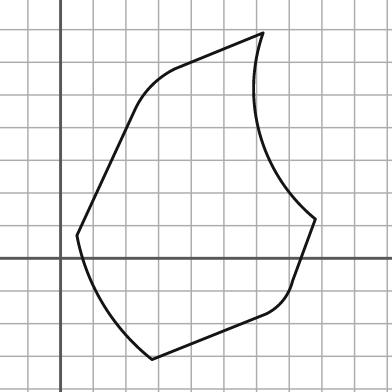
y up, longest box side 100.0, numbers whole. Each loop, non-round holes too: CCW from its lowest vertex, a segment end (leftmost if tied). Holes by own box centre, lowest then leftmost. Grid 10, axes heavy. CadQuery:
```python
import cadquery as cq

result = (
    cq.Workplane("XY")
    .moveTo(28.0, -31.0)
    .lineTo(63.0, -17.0)
    .threePointArc((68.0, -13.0), (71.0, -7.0))
    .lineTo(78.0, 12.0)
    .threePointArc((61.0, 38.0), (62.0, 69.0))
    .lineTo(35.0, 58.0)
    .threePointArc((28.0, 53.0), (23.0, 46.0))
    .lineTo(5.0, 7.0)
    .threePointArc((13.0, -14.0), (28.0, -31.0))
    .close()
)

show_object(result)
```